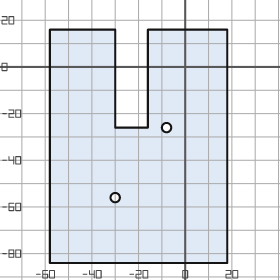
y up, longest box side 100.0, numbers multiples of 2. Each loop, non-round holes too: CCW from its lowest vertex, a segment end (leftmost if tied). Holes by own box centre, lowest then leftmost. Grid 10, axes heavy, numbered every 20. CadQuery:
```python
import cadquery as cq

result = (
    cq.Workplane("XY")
    .moveTo(-58.0, -84.0)
    .lineTo(18.0, -84.0)
    .lineTo(18.0, 16.0)
    .lineTo(-16.0, 16.0)
    .lineTo(-16.0, -26.0)
    .lineTo(-30.0, -26.0)
    .lineTo(-30.0, 16.0)
    .lineTo(-58.0, 16.0)
    .close()
    .moveTo(-30.0, -56.0)
    .circle(2.0)
    .moveTo(-8.0, -26.0)
    .circle(2.0)
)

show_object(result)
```